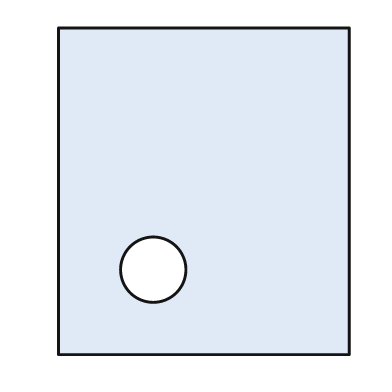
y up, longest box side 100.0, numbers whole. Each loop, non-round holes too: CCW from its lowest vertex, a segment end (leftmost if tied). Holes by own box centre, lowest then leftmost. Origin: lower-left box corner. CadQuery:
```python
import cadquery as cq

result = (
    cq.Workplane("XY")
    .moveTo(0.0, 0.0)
    .lineTo(89.0, 0.0)
    .lineTo(89.0, 100.0)
    .lineTo(0.0, 100.0)
    .close()
    .moveTo(29.0, 26.0)
    .circle(10.0)
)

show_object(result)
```